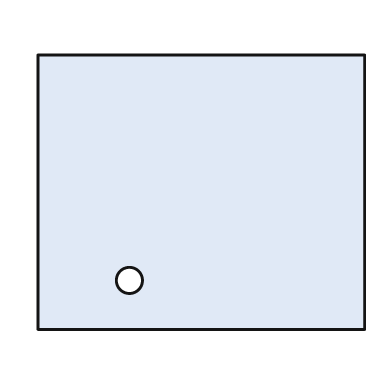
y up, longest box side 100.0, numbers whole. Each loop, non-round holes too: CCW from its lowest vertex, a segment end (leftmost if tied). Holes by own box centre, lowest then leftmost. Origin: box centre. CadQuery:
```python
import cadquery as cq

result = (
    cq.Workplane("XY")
    .moveTo(-50.0, -42.0)
    .lineTo(50.0, -42.0)
    .lineTo(50.0, 42.0)
    .lineTo(-50.0, 42.0)
    .close()
    .moveTo(-22.0, -27.0)
    .circle(4.0)
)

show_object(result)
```